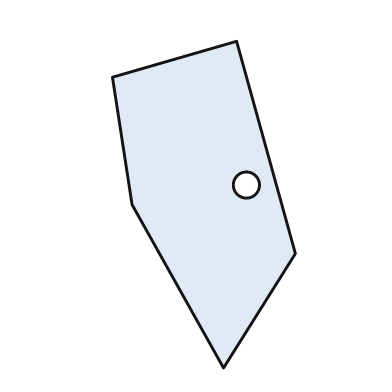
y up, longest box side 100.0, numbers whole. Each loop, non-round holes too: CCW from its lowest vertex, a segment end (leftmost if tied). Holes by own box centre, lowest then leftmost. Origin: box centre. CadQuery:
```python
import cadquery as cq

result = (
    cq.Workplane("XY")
    .moveTo(6.0, -50.0)
    .lineTo(28.0, -15.0)
    .lineTo(10.0, 50.0)
    .lineTo(-28.0, 39.0)
    .lineTo(-22.0, 0.0)
    .close()
    .moveTo(13.0, 6.0)
    .circle(4.0)
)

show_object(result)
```